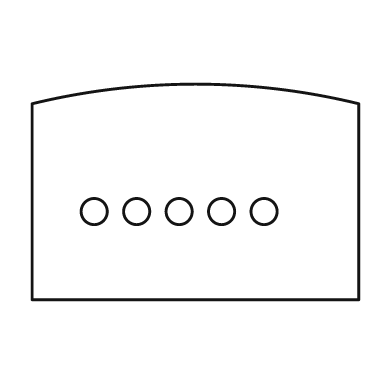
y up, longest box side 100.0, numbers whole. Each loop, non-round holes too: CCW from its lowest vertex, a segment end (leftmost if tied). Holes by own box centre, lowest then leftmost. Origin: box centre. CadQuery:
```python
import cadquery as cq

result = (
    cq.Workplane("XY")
    .moveTo(-50.0, -33.0)
    .lineTo(50.0, -33.0)
    .lineTo(50.0, 27.0)
    .threePointArc((0.0, 33.0), (-50.0, 27.0))
    .close()
    .moveTo(-31.0, -6.0)
    .circle(4.0)
    .moveTo(-18.0, -6.0)
    .circle(4.0)
    .moveTo(-5.0, -6.0)
    .circle(4.0)
    .moveTo(8.0, -6.0)
    .circle(4.0)
    .moveTo(21.0, -6.0)
    .circle(4.0)
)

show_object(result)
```